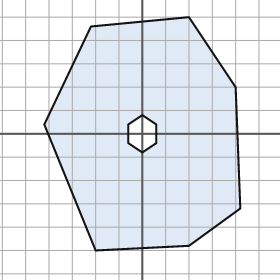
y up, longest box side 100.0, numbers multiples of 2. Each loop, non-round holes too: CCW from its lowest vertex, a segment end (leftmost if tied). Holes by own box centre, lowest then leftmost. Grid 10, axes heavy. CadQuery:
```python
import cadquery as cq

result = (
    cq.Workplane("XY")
    .moveTo(-20.0, -50.0)
    .lineTo(20.0, -48.0)
    .lineTo(42.0, -32.0)
    .lineTo(40.0, 20.0)
    .lineTo(20.0, 50.0)
    .lineTo(-22.0, 46.0)
    .lineTo(-42.0, 4.0)
    .close()
    .moveTo(0.0, -8.0)
    .lineTo(6.0, -4.0)
    .lineTo(6.0, 4.0)
    .lineTo(0.0, 8.0)
    .lineTo(-6.0, 4.0)
    .lineTo(-6.0, -4.0)
    .close()
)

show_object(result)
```